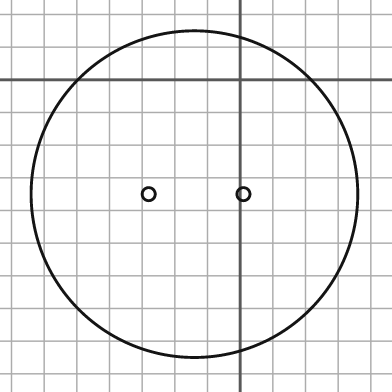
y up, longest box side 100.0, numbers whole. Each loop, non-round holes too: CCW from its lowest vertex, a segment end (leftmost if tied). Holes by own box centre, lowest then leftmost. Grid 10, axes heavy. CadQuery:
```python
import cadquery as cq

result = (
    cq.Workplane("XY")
    .moveTo(-14.0, -35.0)
    .circle(50.0)
    .moveTo(-28.0, -35.0)
    .circle(2.0)
    .moveTo(1.0, -35.0)
    .circle(2.0)
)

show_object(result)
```